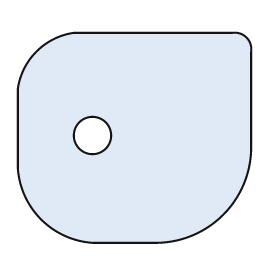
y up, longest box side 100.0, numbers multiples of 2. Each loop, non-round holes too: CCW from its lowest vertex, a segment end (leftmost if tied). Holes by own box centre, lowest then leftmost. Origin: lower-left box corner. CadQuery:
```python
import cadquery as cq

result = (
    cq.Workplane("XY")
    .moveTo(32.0, 0.0)
    .lineTo(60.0, 0.0)
    .threePointArc((88.0, 12.0), (100.0, 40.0))
    .lineTo(100.0, 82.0)
    .threePointArc((98.0, 88.0), (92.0, 90.0))
    .lineTo(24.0, 90.0)
    .threePointArc((8.0, 82.0), (0.0, 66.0))
    .lineTo(0.0, 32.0)
    .threePointArc((10.0, 10.0), (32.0, 0.0))
    .close()
    .moveTo(32.0, 46.0)
    .circle(8.0)
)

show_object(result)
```